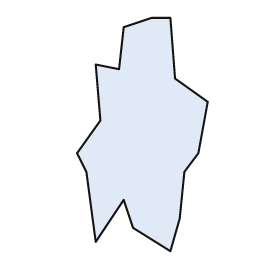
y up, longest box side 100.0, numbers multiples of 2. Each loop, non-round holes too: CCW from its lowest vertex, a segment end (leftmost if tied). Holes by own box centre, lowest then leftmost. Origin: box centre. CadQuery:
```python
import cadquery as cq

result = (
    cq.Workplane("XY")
    .moveTo(12.0, -50.0)
    .lineTo(16.0, -36.0)
    .lineTo(18.0, -16.0)
    .lineTo(24.0, -8.0)
    .lineTo(28.0, 14.0)
    .lineTo(14.0, 24.0)
    .lineTo(12.0, 50.0)
    .lineTo(4.0, 50.0)
    .lineTo(-8.0, 46.0)
    .lineTo(-10.0, 28.0)
    .lineTo(-20.0, 30.0)
    .lineTo(-18.0, 6.0)
    .lineTo(-28.0, -8.0)
    .lineTo(-24.0, -16.0)
    .lineTo(-20.0, -46.0)
    .lineTo(-8.0, -28.0)
    .lineTo(-4.0, -40.0)
    .close()
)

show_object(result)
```